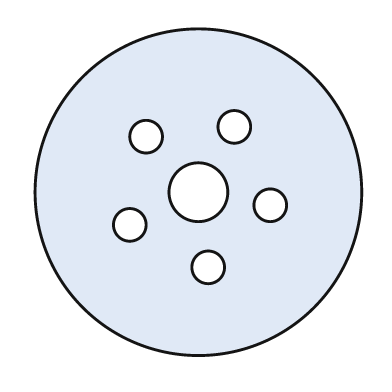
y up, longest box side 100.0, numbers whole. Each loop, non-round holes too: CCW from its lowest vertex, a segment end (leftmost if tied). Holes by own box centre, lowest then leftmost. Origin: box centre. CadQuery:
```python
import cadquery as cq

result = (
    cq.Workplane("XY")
    .moveTo(0.0, 0.0)
    .circle(50.0)
    .moveTo(3.0, -23.0)
    .circle(5.0)
    .moveTo(-21.0, -10.0)
    .circle(5.0)
    .moveTo(22.0, -4.0)
    .circle(5.0)
    .moveTo(0.0, 0.0)
    .circle(9.0)
    .moveTo(-16.0, 17.0)
    .circle(5.0)
    .moveTo(11.0, 20.0)
    .circle(5.0)
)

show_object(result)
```